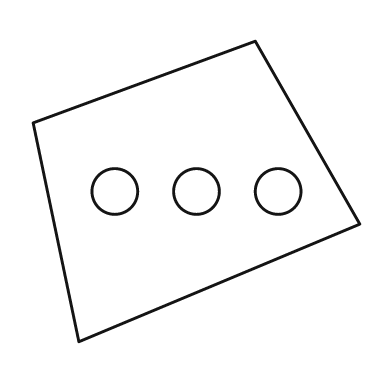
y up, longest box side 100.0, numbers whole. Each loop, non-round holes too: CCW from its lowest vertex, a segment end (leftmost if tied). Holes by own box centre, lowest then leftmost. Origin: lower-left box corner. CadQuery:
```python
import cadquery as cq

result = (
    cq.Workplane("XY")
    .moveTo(14.0, 0.0)
    .lineTo(100.0, 36.0)
    .lineTo(68.0, 92.0)
    .lineTo(0.0, 67.0)
    .close()
    .moveTo(25.0, 46.0)
    .circle(7.0)
    .moveTo(50.0, 46.0)
    .circle(7.0)
    .moveTo(75.0, 46.0)
    .circle(7.0)
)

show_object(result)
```